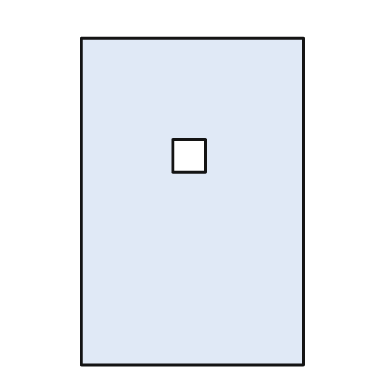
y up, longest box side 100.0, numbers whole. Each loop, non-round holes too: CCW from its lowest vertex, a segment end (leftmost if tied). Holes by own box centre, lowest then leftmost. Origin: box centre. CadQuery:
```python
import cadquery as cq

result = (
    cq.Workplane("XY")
    .moveTo(-34.0, -50.0)
    .lineTo(34.0, -50.0)
    .lineTo(34.0, 50.0)
    .lineTo(-34.0, 50.0)
    .close()
    .moveTo(-6.0, 9.0)
    .lineTo(4.0, 9.0)
    .lineTo(4.0, 19.0)
    .lineTo(-6.0, 19.0)
    .close()
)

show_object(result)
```